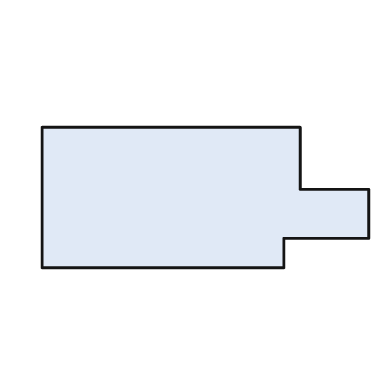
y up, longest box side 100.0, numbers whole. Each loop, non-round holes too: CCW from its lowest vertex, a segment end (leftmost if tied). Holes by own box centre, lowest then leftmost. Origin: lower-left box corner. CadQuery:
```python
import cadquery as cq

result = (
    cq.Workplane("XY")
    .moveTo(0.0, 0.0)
    .lineTo(74.0, 0.0)
    .lineTo(74.0, 9.0)
    .lineTo(100.0, 9.0)
    .lineTo(100.0, 24.0)
    .lineTo(79.0, 24.0)
    .lineTo(79.0, 43.0)
    .lineTo(0.0, 43.0)
    .close()
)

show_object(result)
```